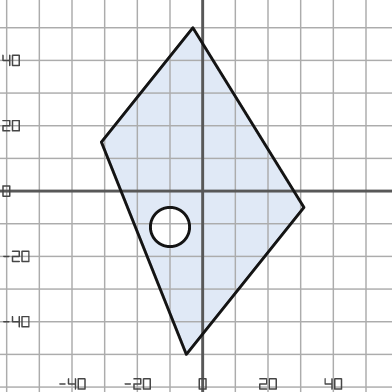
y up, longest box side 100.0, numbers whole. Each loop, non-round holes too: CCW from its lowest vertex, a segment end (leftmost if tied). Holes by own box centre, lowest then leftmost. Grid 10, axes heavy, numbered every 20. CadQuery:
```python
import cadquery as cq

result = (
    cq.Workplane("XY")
    .moveTo(-5.0, -50.0)
    .lineTo(31.0, -5.0)
    .lineTo(-3.0, 50.0)
    .lineTo(-31.0, 15.0)
    .close()
    .moveTo(-10.0, -11.0)
    .circle(6.0)
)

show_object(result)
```